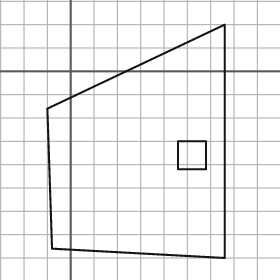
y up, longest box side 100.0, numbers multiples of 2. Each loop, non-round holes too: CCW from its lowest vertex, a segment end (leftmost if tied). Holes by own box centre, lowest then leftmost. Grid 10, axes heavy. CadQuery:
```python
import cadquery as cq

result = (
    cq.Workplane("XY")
    .moveTo(66.0, -80.0)
    .lineTo(66.0, 20.0)
    .lineTo(-10.0, -16.0)
    .lineTo(-8.0, -76.0)
    .close()
    .moveTo(46.0, -42.0)
    .lineTo(58.0, -42.0)
    .lineTo(58.0, -30.0)
    .lineTo(46.0, -30.0)
    .close()
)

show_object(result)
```